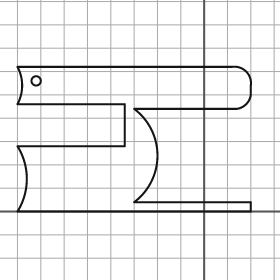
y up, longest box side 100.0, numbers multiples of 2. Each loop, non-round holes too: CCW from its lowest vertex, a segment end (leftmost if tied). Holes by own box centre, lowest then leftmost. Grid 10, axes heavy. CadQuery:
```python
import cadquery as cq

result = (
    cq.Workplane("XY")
    .moveTo(-80.0, 0.0)
    .lineTo(20.0, 0.0)
    .lineTo(20.0, 4.0)
    .lineTo(-30.0, 4.0)
    .threePointArc((-20.0, 24.0), (-30.0, 44.0))
    .lineTo(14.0, 44.0)
    .threePointArc((18.0, 46.0), (20.0, 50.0))
    .lineTo(20.0, 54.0)
    .threePointArc((18.0, 60.0), (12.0, 62.0))
    .lineTo(-80.0, 62.0)
    .threePointArc((-78.0, 54.0), (-80.0, 46.0))
    .lineTo(-34.0, 46.0)
    .lineTo(-34.0, 28.0)
    .lineTo(-80.0, 28.0)
    .threePointArc((-76.0, 14.0), (-80.0, 0.0))
    .close()
    .moveTo(-72.0, 56.0)
    .circle(2.0)
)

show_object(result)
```